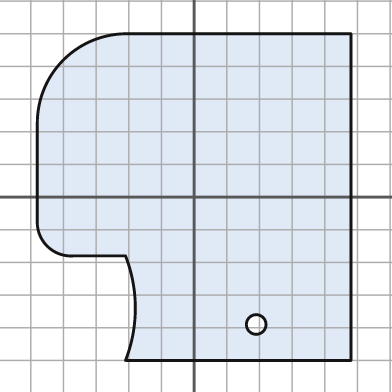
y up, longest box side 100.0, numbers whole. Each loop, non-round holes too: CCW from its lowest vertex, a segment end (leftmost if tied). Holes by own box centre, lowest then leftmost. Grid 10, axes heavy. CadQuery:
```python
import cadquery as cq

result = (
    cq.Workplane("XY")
    .moveTo(-21.0, -50.0)
    .lineTo(48.0, -50.0)
    .lineTo(48.0, 50.0)
    .lineTo(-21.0, 50.0)
    .threePointArc((-40.0, 42.0), (-48.0, 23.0))
    .lineTo(-48.0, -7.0)
    .threePointArc((-45.0, -15.0), (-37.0, -18.0))
    .lineTo(-21.0, -18.0)
    .threePointArc((-18.0, -34.0), (-21.0, -50.0))
    .close()
    .moveTo(19.0, -39.0)
    .circle(3.0)
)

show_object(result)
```